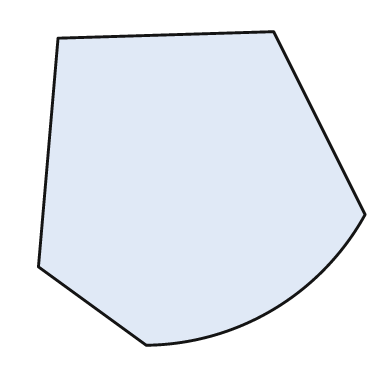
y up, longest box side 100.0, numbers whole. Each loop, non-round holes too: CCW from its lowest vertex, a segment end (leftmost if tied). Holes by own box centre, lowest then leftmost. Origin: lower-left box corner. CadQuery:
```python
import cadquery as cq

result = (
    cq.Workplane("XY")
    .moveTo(33.0, 0.0)
    .threePointArc((72.0, 11.0), (100.0, 40.0))
    .lineTo(72.0, 96.0)
    .lineTo(6.0, 94.0)
    .lineTo(0.0, 24.0)
    .close()
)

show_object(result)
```